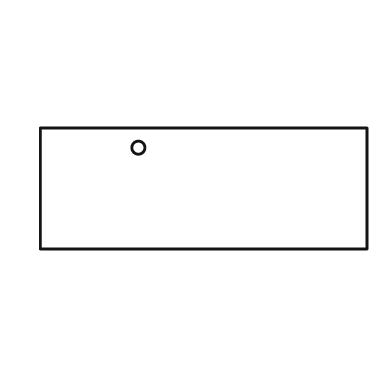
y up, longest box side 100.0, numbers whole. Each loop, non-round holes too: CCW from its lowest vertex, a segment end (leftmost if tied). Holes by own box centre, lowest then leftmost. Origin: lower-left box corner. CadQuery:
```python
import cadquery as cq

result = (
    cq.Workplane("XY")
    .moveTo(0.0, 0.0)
    .lineTo(100.0, 0.0)
    .lineTo(100.0, 37.0)
    .lineTo(0.0, 37.0)
    .close()
    .moveTo(30.0, 31.0)
    .circle(2.0)
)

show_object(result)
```